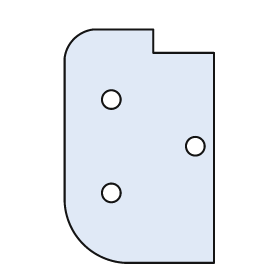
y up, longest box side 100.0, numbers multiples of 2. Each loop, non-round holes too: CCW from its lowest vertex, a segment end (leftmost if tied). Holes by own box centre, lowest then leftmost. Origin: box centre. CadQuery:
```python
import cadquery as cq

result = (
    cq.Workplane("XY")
    .moveTo(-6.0, -50.0)
    .lineTo(32.0, -50.0)
    .lineTo(32.0, 40.0)
    .lineTo(6.0, 40.0)
    .lineTo(6.0, 50.0)
    .lineTo(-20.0, 50.0)
    .threePointArc((-28.0, 46.0), (-32.0, 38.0))
    .lineTo(-32.0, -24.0)
    .threePointArc((-24.0, -42.0), (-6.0, -50.0))
    .close()
    .moveTo(-12.0, -20.0)
    .circle(4.0)
    .moveTo(24.0, 0.0)
    .circle(4.0)
    .moveTo(-12.0, 20.0)
    .circle(4.0)
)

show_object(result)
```